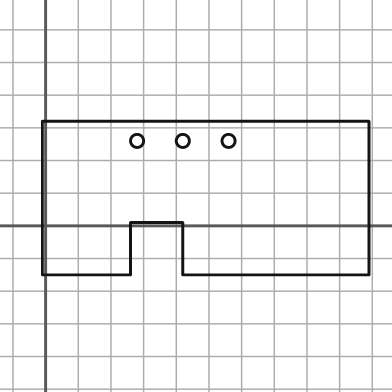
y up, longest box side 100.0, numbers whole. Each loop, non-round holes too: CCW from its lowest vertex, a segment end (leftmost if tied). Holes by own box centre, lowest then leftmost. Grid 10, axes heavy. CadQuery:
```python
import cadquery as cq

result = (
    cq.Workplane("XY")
    .moveTo(-1.0, -15.0)
    .lineTo(26.0, -15.0)
    .lineTo(26.0, 1.0)
    .lineTo(42.0, 1.0)
    .lineTo(42.0, -15.0)
    .lineTo(99.0, -15.0)
    .lineTo(99.0, 32.0)
    .lineTo(-1.0, 32.0)
    .close()
    .moveTo(28.0, 26.0)
    .circle(2.0)
    .moveTo(42.0, 26.0)
    .circle(2.0)
    .moveTo(56.0, 26.0)
    .circle(2.0)
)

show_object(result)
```